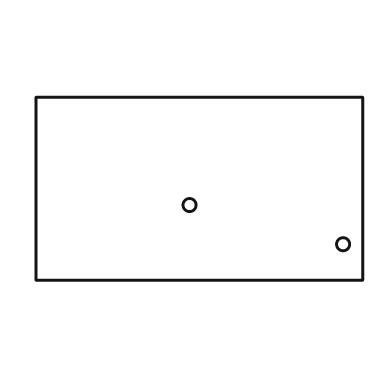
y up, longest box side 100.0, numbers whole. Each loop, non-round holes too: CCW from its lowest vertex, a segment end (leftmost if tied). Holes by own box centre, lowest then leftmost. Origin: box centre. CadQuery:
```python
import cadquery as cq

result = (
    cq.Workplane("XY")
    .moveTo(-50.0, -28.0)
    .lineTo(50.0, -28.0)
    .lineTo(50.0, 28.0)
    .lineTo(-50.0, 28.0)
    .close()
    .moveTo(44.0, -17.0)
    .circle(2.0)
    .moveTo(-3.0, -5.0)
    .circle(2.0)
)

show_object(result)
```